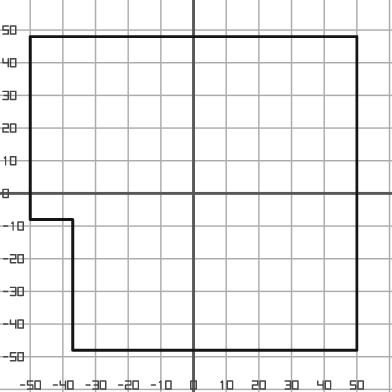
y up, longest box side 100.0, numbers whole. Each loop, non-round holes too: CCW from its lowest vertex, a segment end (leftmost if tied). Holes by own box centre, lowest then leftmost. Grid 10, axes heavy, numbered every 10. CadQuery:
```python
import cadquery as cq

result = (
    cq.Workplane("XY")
    .moveTo(-37.0, -48.0)
    .lineTo(50.0, -48.0)
    .lineTo(50.0, 48.0)
    .lineTo(-50.0, 48.0)
    .lineTo(-50.0, -8.0)
    .lineTo(-37.0, -8.0)
    .close()
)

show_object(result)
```